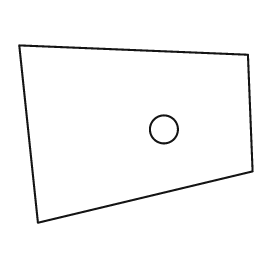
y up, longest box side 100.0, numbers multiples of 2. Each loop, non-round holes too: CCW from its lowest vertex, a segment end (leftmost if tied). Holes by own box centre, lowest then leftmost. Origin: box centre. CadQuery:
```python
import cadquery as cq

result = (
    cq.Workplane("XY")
    .moveTo(-42.0, -38.0)
    .lineTo(50.0, -16.0)
    .lineTo(48.0, 34.0)
    .lineTo(-50.0, 38.0)
    .close()
    .moveTo(12.0, 2.0)
    .circle(6.0)
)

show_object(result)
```